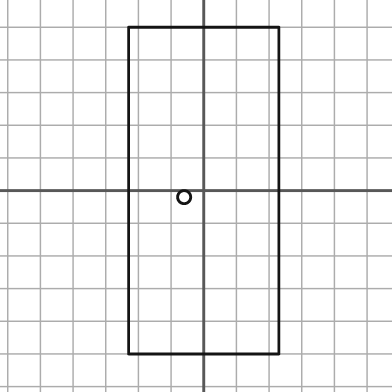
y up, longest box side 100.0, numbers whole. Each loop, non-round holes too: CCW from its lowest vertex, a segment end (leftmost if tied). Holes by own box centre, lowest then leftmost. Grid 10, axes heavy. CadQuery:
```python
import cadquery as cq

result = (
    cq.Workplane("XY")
    .moveTo(-23.0, -50.0)
    .lineTo(23.0, -50.0)
    .lineTo(23.0, 50.0)
    .lineTo(-23.0, 50.0)
    .close()
    .moveTo(-6.0, -2.0)
    .circle(2.0)
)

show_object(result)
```